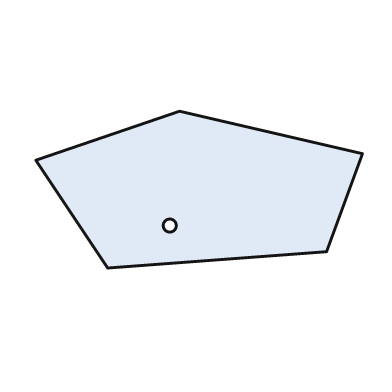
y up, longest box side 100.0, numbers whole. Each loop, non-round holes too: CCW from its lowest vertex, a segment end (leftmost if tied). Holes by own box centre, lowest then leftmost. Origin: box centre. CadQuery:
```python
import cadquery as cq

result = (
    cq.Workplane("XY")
    .moveTo(-28.0, -24.0)
    .lineTo(39.0, -19.0)
    .lineTo(50.0, 11.0)
    .lineTo(-6.0, 24.0)
    .lineTo(-50.0, 9.0)
    .close()
    .moveTo(-9.0, -11.0)
    .circle(2.0)
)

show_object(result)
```